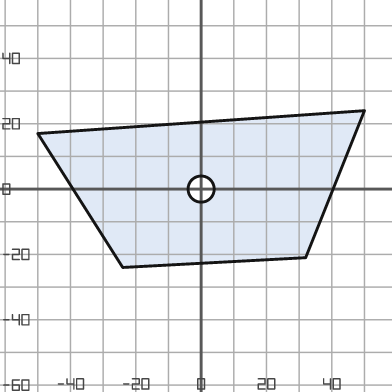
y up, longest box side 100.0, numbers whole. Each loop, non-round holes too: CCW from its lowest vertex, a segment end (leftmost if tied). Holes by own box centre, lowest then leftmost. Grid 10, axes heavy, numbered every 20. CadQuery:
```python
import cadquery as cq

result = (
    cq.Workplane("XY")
    .moveTo(-24.0, -24.0)
    .lineTo(32.0, -21.0)
    .lineTo(50.0, 24.0)
    .lineTo(-50.0, 17.0)
    .close()
    .moveTo(0.0, 0.0)
    .circle(4.0)
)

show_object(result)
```